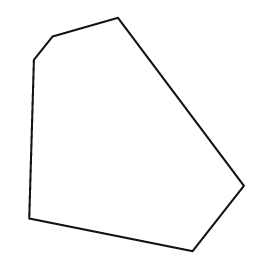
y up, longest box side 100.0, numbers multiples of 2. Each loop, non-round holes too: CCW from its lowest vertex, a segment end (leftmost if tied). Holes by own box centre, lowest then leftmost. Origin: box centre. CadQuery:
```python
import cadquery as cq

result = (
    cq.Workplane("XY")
    .moveTo(24.0, -50.0)
    .lineTo(46.0, -22.0)
    .lineTo(-8.0, 50.0)
    .lineTo(-36.0, 42.0)
    .lineTo(-44.0, 32.0)
    .lineTo(-46.0, -36.0)
    .close()
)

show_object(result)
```